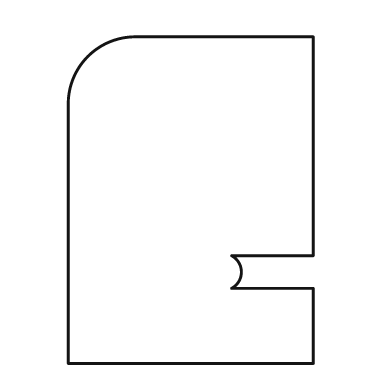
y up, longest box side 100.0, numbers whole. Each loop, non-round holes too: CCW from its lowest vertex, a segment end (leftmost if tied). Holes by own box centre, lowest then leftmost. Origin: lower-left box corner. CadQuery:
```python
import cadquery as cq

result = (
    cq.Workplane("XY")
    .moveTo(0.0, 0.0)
    .lineTo(75.0, 0.0)
    .lineTo(75.0, 23.0)
    .lineTo(50.0, 23.0)
    .threePointArc((53.0, 28.0), (50.0, 33.0))
    .lineTo(75.0, 33.0)
    .lineTo(75.0, 100.0)
    .lineTo(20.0, 100.0)
    .threePointArc((6.0, 94.0), (0.0, 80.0))
    .close()
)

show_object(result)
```